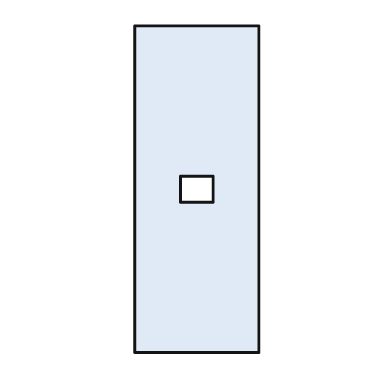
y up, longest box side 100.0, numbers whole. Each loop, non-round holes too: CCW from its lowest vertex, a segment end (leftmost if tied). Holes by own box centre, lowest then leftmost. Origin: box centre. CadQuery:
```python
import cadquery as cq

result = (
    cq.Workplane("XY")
    .moveTo(-19.0, -50.0)
    .lineTo(19.0, -50.0)
    .lineTo(19.0, 50.0)
    .lineTo(-19.0, 50.0)
    .close()
    .moveTo(-5.0, -4.0)
    .lineTo(5.0, -4.0)
    .lineTo(5.0, 4.0)
    .lineTo(-5.0, 4.0)
    .close()
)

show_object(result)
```